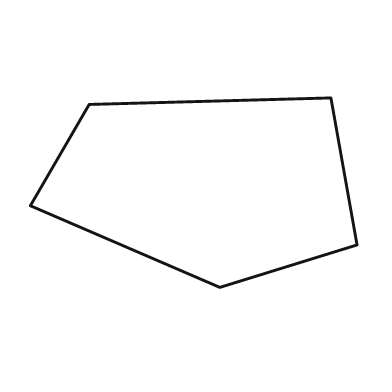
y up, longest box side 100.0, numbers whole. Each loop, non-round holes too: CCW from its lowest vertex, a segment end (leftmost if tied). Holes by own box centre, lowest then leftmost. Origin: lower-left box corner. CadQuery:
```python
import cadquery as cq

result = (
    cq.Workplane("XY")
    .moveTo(58.0, 0.0)
    .lineTo(100.0, 13.0)
    .lineTo(92.0, 58.0)
    .lineTo(18.0, 56.0)
    .lineTo(0.0, 25.0)
    .close()
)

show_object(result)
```